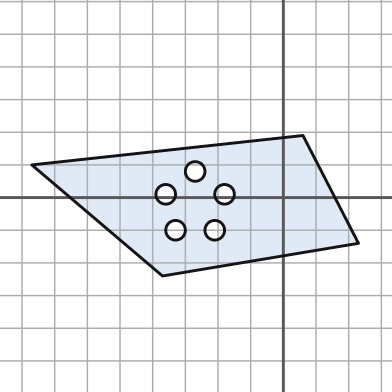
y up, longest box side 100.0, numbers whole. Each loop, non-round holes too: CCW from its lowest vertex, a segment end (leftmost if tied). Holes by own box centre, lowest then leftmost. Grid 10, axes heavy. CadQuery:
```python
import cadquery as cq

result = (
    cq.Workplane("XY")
    .moveTo(-37.0, -24.0)
    .lineTo(23.0, -14.0)
    .lineTo(6.0, 19.0)
    .lineTo(-77.0, 10.0)
    .close()
    .moveTo(-33.0, -10.0)
    .circle(3.0)
    .moveTo(-21.0, -10.0)
    .circle(3.0)
    .moveTo(-36.0, 1.0)
    .circle(3.0)
    .moveTo(-18.0, 1.0)
    .circle(3.0)
    .moveTo(-27.0, 8.0)
    .circle(3.0)
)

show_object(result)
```